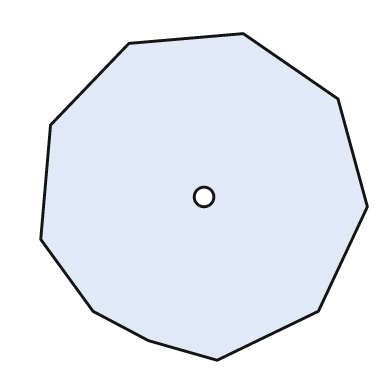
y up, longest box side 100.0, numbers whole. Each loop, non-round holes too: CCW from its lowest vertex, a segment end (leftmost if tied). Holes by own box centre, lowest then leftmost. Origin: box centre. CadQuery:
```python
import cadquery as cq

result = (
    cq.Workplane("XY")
    .moveTo(4.0, -50.0)
    .lineTo(35.0, -35.0)
    .lineTo(50.0, -3.0)
    .lineTo(41.0, 30.0)
    .lineTo(12.0, 50.0)
    .lineTo(-23.0, 47.0)
    .lineTo(-47.0, 22.0)
    .lineTo(-50.0, -13.0)
    .lineTo(-34.0, -35.0)
    .lineTo(-17.0, -44.0)
    .close()
    .moveTo(0.0, 0.0)
    .circle(3.0)
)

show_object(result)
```